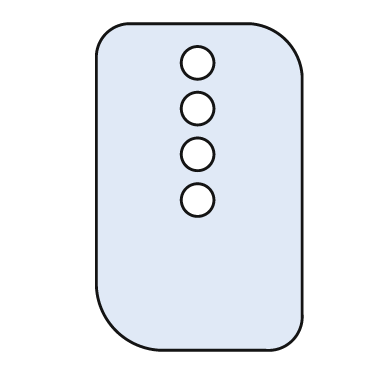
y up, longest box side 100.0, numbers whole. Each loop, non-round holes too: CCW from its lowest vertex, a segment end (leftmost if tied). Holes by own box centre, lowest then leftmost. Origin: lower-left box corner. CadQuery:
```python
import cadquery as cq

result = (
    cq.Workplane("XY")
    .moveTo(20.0, 0.0)
    .lineTo(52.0, 0.0)
    .threePointArc((60.0, 3.0), (63.0, 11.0))
    .lineTo(63.0, 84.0)
    .threePointArc((58.0, 95.0), (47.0, 100.0))
    .lineTo(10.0, 100.0)
    .threePointArc((3.0, 97.0), (0.0, 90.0))
    .lineTo(0.0, 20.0)
    .threePointArc((6.0, 6.0), (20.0, 0.0))
    .close()
    .moveTo(31.0, 46.0)
    .circle(5.0)
    .moveTo(31.0, 60.0)
    .circle(5.0)
    .moveTo(31.0, 74.0)
    .circle(5.0)
    .moveTo(31.0, 88.0)
    .circle(5.0)
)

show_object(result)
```